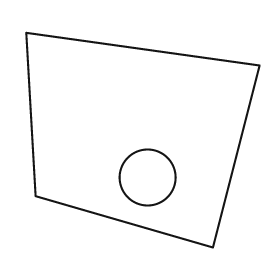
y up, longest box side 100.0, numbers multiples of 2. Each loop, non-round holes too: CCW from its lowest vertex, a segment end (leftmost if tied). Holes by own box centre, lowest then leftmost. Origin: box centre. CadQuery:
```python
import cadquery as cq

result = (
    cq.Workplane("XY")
    .moveTo(30.0, -46.0)
    .lineTo(50.0, 32.0)
    .lineTo(-50.0, 46.0)
    .lineTo(-46.0, -24.0)
    .close()
    .moveTo(2.0, -16.0)
    .circle(12.0)
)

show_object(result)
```